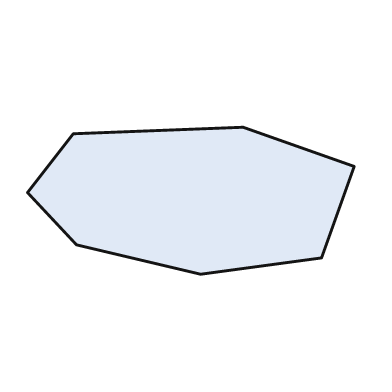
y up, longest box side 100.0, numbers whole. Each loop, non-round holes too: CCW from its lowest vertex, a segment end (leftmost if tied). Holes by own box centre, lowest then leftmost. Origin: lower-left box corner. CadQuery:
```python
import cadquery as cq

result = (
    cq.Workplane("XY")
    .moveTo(53.0, 0.0)
    .lineTo(90.0, 5.0)
    .lineTo(100.0, 33.0)
    .lineTo(66.0, 45.0)
    .lineTo(14.0, 43.0)
    .lineTo(0.0, 25.0)
    .lineTo(15.0, 9.0)
    .close()
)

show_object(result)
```